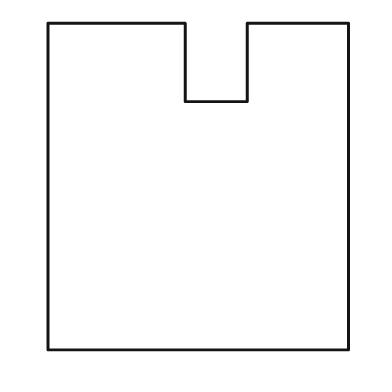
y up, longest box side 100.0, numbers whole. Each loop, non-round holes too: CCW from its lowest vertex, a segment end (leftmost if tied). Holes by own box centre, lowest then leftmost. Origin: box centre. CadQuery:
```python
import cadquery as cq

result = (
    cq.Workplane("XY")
    .moveTo(-46.0, -50.0)
    .lineTo(46.0, -50.0)
    .lineTo(46.0, 50.0)
    .lineTo(15.0, 50.0)
    .lineTo(15.0, 26.0)
    .lineTo(-4.0, 26.0)
    .lineTo(-4.0, 50.0)
    .lineTo(-46.0, 50.0)
    .close()
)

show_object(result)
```